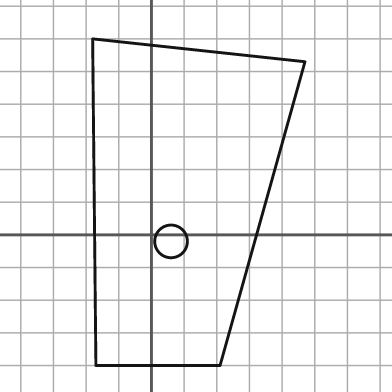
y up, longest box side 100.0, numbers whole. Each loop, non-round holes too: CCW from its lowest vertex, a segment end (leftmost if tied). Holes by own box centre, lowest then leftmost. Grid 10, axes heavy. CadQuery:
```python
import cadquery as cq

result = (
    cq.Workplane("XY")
    .moveTo(-17.0, -40.0)
    .lineTo(21.0, -40.0)
    .lineTo(47.0, 53.0)
    .lineTo(-18.0, 60.0)
    .close()
    .moveTo(6.0, -2.0)
    .circle(5.0)
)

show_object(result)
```